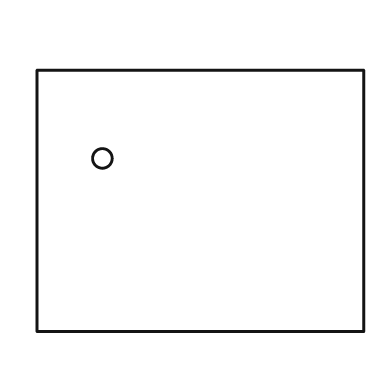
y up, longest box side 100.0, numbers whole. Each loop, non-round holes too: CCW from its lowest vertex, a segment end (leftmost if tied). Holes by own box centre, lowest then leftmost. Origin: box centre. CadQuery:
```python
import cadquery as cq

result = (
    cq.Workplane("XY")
    .moveTo(-50.0, -40.0)
    .lineTo(50.0, -40.0)
    .lineTo(50.0, 40.0)
    .lineTo(-50.0, 40.0)
    .close()
    .moveTo(-30.0, 13.0)
    .circle(3.0)
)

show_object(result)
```